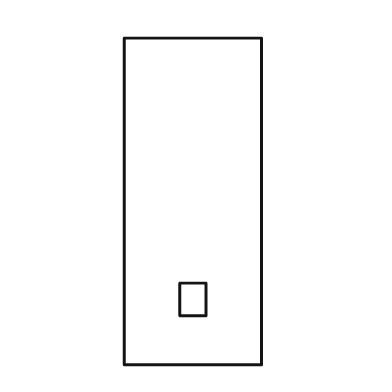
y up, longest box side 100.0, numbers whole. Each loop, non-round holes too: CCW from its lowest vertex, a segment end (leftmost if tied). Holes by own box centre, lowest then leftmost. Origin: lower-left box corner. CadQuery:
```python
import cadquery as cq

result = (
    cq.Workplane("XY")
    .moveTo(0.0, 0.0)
    .lineTo(42.0, 0.0)
    .lineTo(42.0, 100.0)
    .lineTo(0.0, 100.0)
    .close()
    .moveTo(17.0, 15.0)
    .lineTo(25.0, 15.0)
    .lineTo(25.0, 25.0)
    .lineTo(17.0, 25.0)
    .close()
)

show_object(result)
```